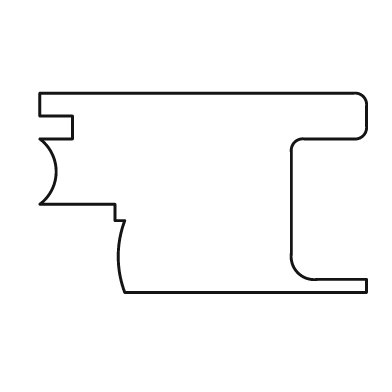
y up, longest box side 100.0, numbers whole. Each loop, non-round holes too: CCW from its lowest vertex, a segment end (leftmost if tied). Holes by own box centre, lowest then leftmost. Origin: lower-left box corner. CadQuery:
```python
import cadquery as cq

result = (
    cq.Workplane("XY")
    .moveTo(26.0, 0.0)
    .lineTo(100.0, 0.0)
    .lineTo(100.0, 4.0)
    .lineTo(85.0, 4.0)
    .threePointArc((79.0, 6.0), (77.0, 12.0))
    .lineTo(77.0, 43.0)
    .threePointArc((78.0, 46.0), (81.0, 47.0))
    .lineTo(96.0, 47.0)
    .threePointArc((99.0, 48.0), (100.0, 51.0))
    .lineTo(100.0, 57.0)
    .threePointArc((99.0, 60.0), (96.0, 61.0))
    .lineTo(0.0, 61.0)
    .lineTo(0.0, 54.0)
    .lineTo(10.0, 54.0)
    .lineTo(10.0, 47.0)
    .lineTo(0.0, 47.0)
    .threePointArc((5.0, 37.0), (0.0, 27.0))
    .lineTo(23.0, 27.0)
    .lineTo(23.0, 22.0)
    .lineTo(26.0, 22.0)
    .threePointArc((24.0, 11.0), (26.0, 0.0))
    .close()
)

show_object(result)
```